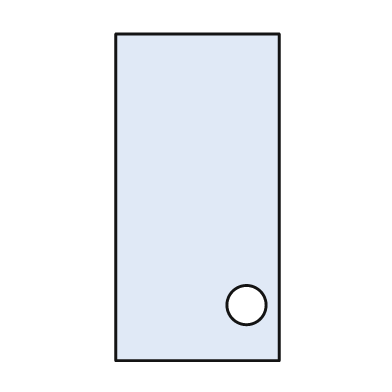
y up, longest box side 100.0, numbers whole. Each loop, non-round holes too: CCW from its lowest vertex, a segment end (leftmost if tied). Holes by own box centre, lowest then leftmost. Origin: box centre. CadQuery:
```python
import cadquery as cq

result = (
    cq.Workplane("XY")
    .moveTo(-25.0, -50.0)
    .lineTo(25.0, -50.0)
    .lineTo(25.0, 50.0)
    .lineTo(-25.0, 50.0)
    .close()
    .moveTo(15.0, -33.0)
    .circle(6.0)
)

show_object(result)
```